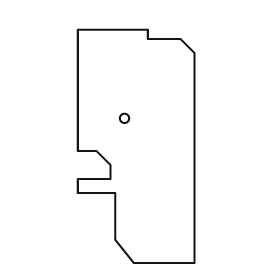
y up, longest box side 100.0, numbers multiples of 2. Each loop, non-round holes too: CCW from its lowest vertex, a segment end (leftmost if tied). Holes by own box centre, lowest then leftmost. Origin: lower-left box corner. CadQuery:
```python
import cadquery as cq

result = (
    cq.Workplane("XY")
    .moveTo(24.0, 0.0)
    .lineTo(50.0, 0.0)
    .lineTo(50.0, 90.0)
    .lineTo(44.0, 96.0)
    .lineTo(30.0, 96.0)
    .lineTo(30.0, 100.0)
    .lineTo(0.0, 100.0)
    .lineTo(0.0, 48.0)
    .lineTo(8.0, 48.0)
    .lineTo(14.0, 42.0)
    .lineTo(14.0, 36.0)
    .lineTo(0.0, 36.0)
    .lineTo(0.0, 30.0)
    .lineTo(16.0, 30.0)
    .lineTo(16.0, 10.0)
    .close()
    .moveTo(20.0, 62.0)
    .circle(2.0)
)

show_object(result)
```